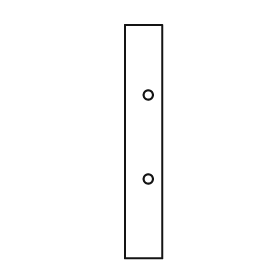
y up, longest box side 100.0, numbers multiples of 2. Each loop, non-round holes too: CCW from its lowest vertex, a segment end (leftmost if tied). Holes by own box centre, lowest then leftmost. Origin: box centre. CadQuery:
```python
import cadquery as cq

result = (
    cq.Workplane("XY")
    .moveTo(-8.0, -50.0)
    .lineTo(8.0, -50.0)
    .lineTo(8.0, 50.0)
    .lineTo(-8.0, 50.0)
    .close()
    .moveTo(2.0, -16.0)
    .circle(2.0)
    .moveTo(2.0, 20.0)
    .circle(2.0)
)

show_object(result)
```